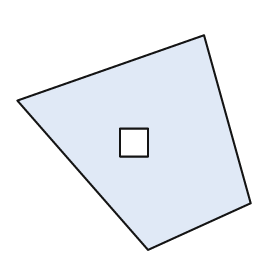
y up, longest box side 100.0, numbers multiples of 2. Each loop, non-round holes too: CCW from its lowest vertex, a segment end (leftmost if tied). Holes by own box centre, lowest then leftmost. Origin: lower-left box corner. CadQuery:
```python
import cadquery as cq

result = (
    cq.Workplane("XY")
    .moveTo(56.0, 0.0)
    .lineTo(100.0, 20.0)
    .lineTo(80.0, 92.0)
    .lineTo(0.0, 64.0)
    .close()
    .moveTo(44.0, 40.0)
    .lineTo(56.0, 40.0)
    .lineTo(56.0, 52.0)
    .lineTo(44.0, 52.0)
    .close()
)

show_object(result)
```